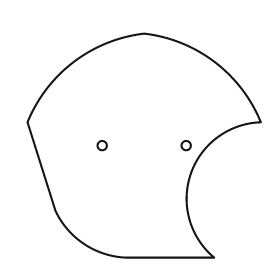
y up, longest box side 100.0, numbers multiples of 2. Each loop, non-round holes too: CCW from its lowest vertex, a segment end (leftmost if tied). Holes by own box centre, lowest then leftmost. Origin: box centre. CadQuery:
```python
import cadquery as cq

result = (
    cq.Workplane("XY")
    .moveTo(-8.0, -48.0)
    .lineTo(30.0, -48.0)
    .threePointArc((20.0, -12.0), (50.0, 10.0))
    .threePointArc((30.0, 36.0), (0.0, 48.0))
    .threePointArc((-30.0, 36.0), (-50.0, 10.0))
    .lineTo(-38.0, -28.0)
    .threePointArc((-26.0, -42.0), (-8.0, -48.0))
    .close()
    .moveTo(-18.0, 0.0)
    .circle(2.0)
    .moveTo(18.0, 0.0)
    .circle(2.0)
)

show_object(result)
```